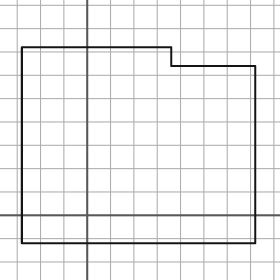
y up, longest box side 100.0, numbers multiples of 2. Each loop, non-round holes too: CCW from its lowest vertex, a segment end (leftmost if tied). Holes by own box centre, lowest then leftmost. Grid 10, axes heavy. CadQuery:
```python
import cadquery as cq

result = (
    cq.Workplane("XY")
    .moveTo(-28.0, -12.0)
    .lineTo(72.0, -12.0)
    .lineTo(72.0, 64.0)
    .lineTo(36.0, 64.0)
    .lineTo(36.0, 72.0)
    .lineTo(-28.0, 72.0)
    .close()
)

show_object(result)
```